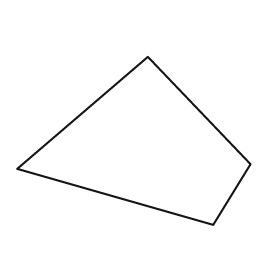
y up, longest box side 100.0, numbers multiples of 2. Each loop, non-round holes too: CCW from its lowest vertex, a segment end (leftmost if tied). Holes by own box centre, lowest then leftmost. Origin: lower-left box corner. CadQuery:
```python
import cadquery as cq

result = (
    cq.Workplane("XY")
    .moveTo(84.0, 0.0)
    .lineTo(100.0, 26.0)
    .lineTo(56.0, 72.0)
    .lineTo(0.0, 24.0)
    .close()
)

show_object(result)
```